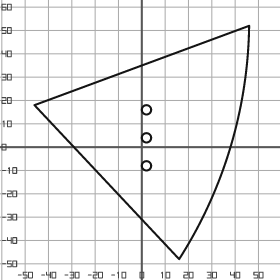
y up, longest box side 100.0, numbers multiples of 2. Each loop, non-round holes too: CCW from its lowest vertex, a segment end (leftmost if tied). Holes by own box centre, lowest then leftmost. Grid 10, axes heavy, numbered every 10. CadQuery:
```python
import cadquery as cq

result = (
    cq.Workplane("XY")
    .moveTo(16.0, -48.0)
    .threePointArc((38.0, 0.0), (46.0, 52.0))
    .lineTo(-46.0, 18.0)
    .close()
    .moveTo(2.0, -8.0)
    .circle(2.0)
    .moveTo(2.0, 4.0)
    .circle(2.0)
    .moveTo(2.0, 16.0)
    .circle(2.0)
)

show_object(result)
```